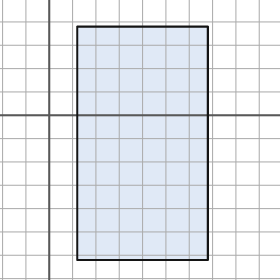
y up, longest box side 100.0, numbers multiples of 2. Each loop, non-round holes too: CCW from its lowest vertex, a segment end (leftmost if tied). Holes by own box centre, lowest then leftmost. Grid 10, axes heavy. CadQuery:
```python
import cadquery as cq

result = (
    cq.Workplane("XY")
    .moveTo(12.0, -62.0)
    .lineTo(68.0, -62.0)
    .lineTo(68.0, 38.0)
    .lineTo(12.0, 38.0)
    .close()
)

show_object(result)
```